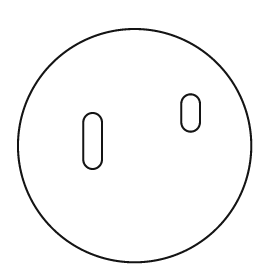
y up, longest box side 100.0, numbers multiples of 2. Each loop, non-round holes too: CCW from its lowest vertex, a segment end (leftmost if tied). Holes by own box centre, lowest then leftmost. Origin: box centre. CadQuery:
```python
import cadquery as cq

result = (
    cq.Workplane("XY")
    .moveTo(0.0, 0.0)
    .circle(50.0)
    .moveTo(-22.0, -6.0)
    .threePointArc((-18.0, -10.0), (-14.0, -6.0))
    .lineTo(-14.0, 10.0)
    .threePointArc((-18.0, 14.0), (-22.0, 10.0))
    .close()
    .moveTo(20.0, 10.0)
    .threePointArc((24.0, 6.0), (28.0, 10.0))
    .lineTo(28.0, 18.0)
    .threePointArc((24.0, 22.0), (20.0, 18.0))
    .close()
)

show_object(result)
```